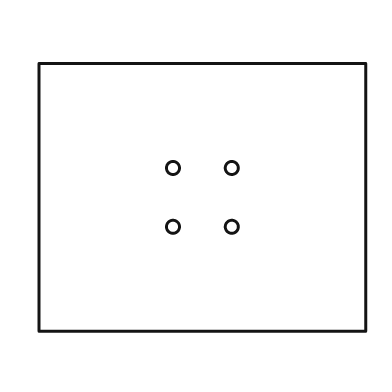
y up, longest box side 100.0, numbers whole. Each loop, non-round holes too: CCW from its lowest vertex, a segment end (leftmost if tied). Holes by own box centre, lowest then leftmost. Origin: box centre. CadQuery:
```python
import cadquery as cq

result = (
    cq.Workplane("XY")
    .moveTo(-50.0, -41.0)
    .lineTo(50.0, -41.0)
    .lineTo(50.0, 41.0)
    .lineTo(-50.0, 41.0)
    .close()
    .moveTo(-9.0, -9.0)
    .circle(2.0)
    .moveTo(9.0, -9.0)
    .circle(2.0)
    .moveTo(-9.0, 9.0)
    .circle(2.0)
    .moveTo(9.0, 9.0)
    .circle(2.0)
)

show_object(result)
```